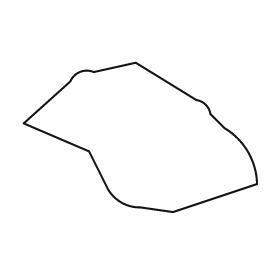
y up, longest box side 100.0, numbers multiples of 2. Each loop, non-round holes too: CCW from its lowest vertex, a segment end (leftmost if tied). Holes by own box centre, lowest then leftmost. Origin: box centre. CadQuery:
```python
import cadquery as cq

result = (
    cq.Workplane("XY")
    .moveTo(14.0, -32.0)
    .lineTo(50.0, -20.0)
    .threePointArc((46.0, -6.0), (36.0, 4.0))
    .lineTo(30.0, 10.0)
    .threePointArc((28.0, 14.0), (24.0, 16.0))
    .lineTo(-2.0, 32.0)
    .lineTo(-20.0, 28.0)
    .threePointArc((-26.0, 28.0), (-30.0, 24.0))
    .lineTo(-50.0, 6.0)
    .lineTo(-22.0, -6.0)
    .lineTo(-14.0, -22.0)
    .threePointArc((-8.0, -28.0), (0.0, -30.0))
    .close()
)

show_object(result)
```